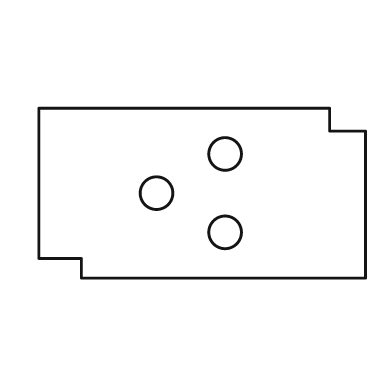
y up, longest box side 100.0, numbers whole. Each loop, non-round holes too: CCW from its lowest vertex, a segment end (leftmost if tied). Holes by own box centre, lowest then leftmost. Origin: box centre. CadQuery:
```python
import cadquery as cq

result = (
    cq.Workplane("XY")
    .moveTo(-37.0, -26.0)
    .lineTo(50.0, -26.0)
    .lineTo(50.0, 19.0)
    .lineTo(39.0, 19.0)
    .lineTo(39.0, 26.0)
    .lineTo(-50.0, 26.0)
    .lineTo(-50.0, -20.0)
    .lineTo(-37.0, -20.0)
    .close()
    .moveTo(7.0, -12.0)
    .circle(5.0)
    .moveTo(-14.0, 0.0)
    .circle(5.0)
    .moveTo(7.0, 12.0)
    .circle(5.0)
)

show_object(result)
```